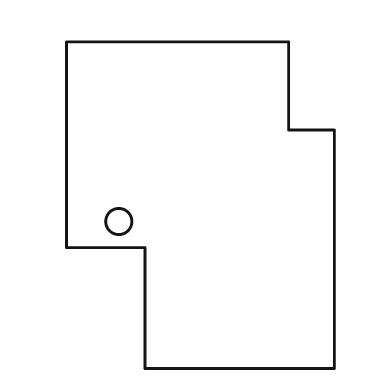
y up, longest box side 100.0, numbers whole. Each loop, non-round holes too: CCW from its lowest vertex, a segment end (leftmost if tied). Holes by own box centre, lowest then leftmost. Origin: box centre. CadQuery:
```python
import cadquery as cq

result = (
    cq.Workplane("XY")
    .moveTo(-17.0, -50.0)
    .lineTo(41.0, -50.0)
    .lineTo(41.0, 23.0)
    .lineTo(27.0, 23.0)
    .lineTo(27.0, 50.0)
    .lineTo(-41.0, 50.0)
    .lineTo(-41.0, -13.0)
    .lineTo(-17.0, -13.0)
    .close()
    .moveTo(-25.0, -5.0)
    .circle(4.0)
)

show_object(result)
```